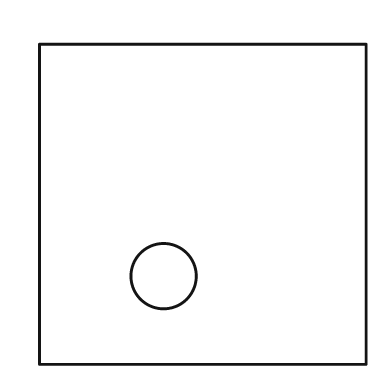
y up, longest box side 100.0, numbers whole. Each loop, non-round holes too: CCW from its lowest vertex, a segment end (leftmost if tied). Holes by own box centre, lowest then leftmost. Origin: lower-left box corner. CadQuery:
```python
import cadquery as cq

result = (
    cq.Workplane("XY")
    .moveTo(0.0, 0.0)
    .lineTo(100.0, 0.0)
    .lineTo(100.0, 98.0)
    .lineTo(0.0, 98.0)
    .close()
    .moveTo(38.0, 27.0)
    .circle(10.0)
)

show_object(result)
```